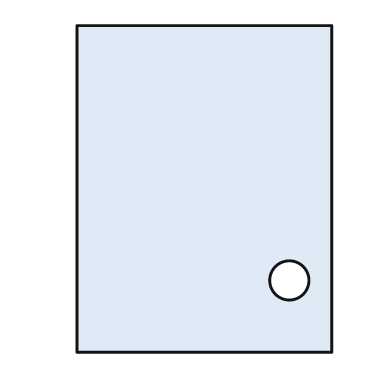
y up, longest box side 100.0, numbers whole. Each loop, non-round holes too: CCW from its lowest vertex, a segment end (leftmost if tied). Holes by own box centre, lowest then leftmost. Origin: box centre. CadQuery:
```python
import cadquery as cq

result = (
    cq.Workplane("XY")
    .moveTo(-39.0, -50.0)
    .lineTo(39.0, -50.0)
    .lineTo(39.0, 50.0)
    .lineTo(-39.0, 50.0)
    .close()
    .moveTo(26.0, -28.0)
    .circle(6.0)
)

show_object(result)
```